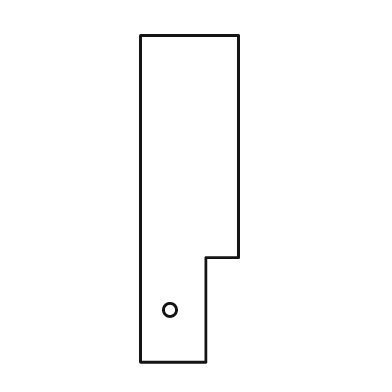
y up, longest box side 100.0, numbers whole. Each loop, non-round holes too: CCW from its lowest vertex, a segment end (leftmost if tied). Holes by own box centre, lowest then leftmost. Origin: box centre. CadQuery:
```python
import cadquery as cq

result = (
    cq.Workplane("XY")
    .moveTo(-15.0, -50.0)
    .lineTo(5.0, -50.0)
    .lineTo(5.0, -18.0)
    .lineTo(15.0, -18.0)
    .lineTo(15.0, 50.0)
    .lineTo(-15.0, 50.0)
    .close()
    .moveTo(-6.0, -34.0)
    .circle(2.0)
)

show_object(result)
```